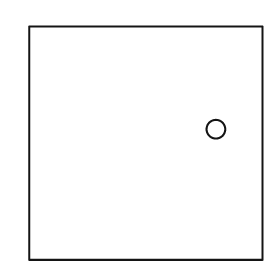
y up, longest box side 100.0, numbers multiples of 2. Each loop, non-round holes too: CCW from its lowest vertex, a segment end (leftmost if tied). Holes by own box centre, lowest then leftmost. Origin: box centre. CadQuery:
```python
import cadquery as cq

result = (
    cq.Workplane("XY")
    .moveTo(-50.0, -50.0)
    .lineTo(50.0, -50.0)
    .lineTo(50.0, 50.0)
    .lineTo(-50.0, 50.0)
    .close()
    .moveTo(30.0, 6.0)
    .circle(4.0)
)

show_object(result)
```